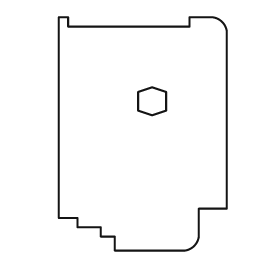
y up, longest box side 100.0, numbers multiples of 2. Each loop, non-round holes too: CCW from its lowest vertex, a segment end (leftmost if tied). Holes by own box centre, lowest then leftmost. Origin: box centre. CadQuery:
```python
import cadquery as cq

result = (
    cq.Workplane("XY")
    .moveTo(-12.0, -50.0)
    .lineTo(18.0, -50.0)
    .threePointArc((22.0, -48.0), (24.0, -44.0))
    .lineTo(24.0, -32.0)
    .lineTo(36.0, -32.0)
    .lineTo(36.0, 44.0)
    .threePointArc((34.0, 48.0), (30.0, 50.0))
    .lineTo(20.0, 50.0)
    .lineTo(20.0, 46.0)
    .lineTo(-32.0, 46.0)
    .lineTo(-32.0, 50.0)
    .lineTo(-36.0, 50.0)
    .lineTo(-36.0, -36.0)
    .lineTo(-28.0, -36.0)
    .lineTo(-28.0, -40.0)
    .lineTo(-18.0, -40.0)
    .lineTo(-18.0, -44.0)
    .lineTo(-12.0, -44.0)
    .close()
    .moveTo(4.0, 8.0)
    .lineTo(10.0, 10.0)
    .lineTo(10.0, 18.0)
    .lineTo(4.0, 20.0)
    .lineTo(-2.0, 18.0)
    .lineTo(-2.0, 10.0)
    .close()
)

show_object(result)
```